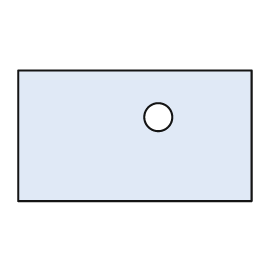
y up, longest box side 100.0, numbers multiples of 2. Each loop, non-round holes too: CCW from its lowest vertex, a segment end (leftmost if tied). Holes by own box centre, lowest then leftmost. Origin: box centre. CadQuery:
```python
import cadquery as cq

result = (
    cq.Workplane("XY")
    .moveTo(-50.0, -28.0)
    .lineTo(50.0, -28.0)
    .lineTo(50.0, 28.0)
    .lineTo(-50.0, 28.0)
    .close()
    .moveTo(10.0, 8.0)
    .circle(6.0)
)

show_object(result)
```